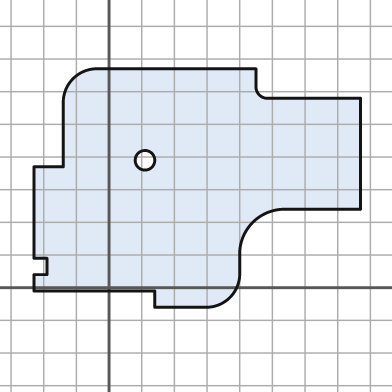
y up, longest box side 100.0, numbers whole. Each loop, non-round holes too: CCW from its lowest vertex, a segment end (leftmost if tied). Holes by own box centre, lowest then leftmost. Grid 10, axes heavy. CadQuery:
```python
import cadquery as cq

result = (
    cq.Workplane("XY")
    .moveTo(14.0, -6.0)
    .lineTo(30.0, -6.0)
    .threePointArc((37.0, -3.0), (40.0, 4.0))
    .lineTo(40.0, 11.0)
    .threePointArc((44.0, 20.0), (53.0, 24.0))
    .lineTo(77.0, 24.0)
    .lineTo(77.0, 58.0)
    .lineTo(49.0, 58.0)
    .threePointArc((46.0, 59.0), (45.0, 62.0))
    .lineTo(45.0, 67.0)
    .lineTo(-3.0, 67.0)
    .threePointArc((-11.0, 64.0), (-14.0, 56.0))
    .lineTo(-14.0, 37.0)
    .lineTo(-23.0, 37.0)
    .lineTo(-23.0, 9.0)
    .lineTo(-19.0, 9.0)
    .lineTo(-19.0, 4.0)
    .lineTo(-23.0, 4.0)
    .lineTo(-23.0, -1.0)
    .lineTo(14.0, -1.0)
    .close()
    .moveTo(11.0, 39.0)
    .circle(3.0)
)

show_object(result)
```